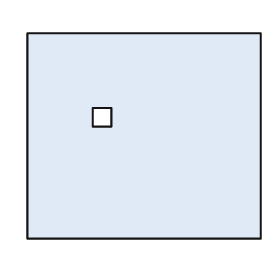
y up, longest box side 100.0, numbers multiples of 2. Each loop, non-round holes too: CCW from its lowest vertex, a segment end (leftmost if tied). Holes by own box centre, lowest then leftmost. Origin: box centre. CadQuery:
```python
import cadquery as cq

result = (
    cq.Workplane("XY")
    .moveTo(-50.0, -44.0)
    .lineTo(50.0, -44.0)
    .lineTo(50.0, 44.0)
    .lineTo(-50.0, 44.0)
    .close()
    .moveTo(-22.0, 4.0)
    .lineTo(-14.0, 4.0)
    .lineTo(-14.0, 12.0)
    .lineTo(-22.0, 12.0)
    .close()
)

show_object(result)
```